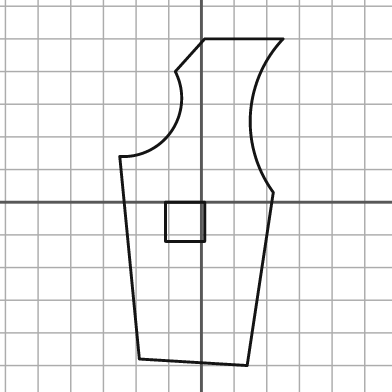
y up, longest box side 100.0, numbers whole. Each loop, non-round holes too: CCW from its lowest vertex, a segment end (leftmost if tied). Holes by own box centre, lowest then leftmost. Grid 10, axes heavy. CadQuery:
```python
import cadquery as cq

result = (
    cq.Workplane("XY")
    .moveTo(14.0, -50.0)
    .lineTo(22.0, 3.0)
    .threePointArc((15.0, 27.0), (25.0, 50.0))
    .lineTo(1.0, 50.0)
    .lineTo(-8.0, 40.0)
    .threePointArc((-9.0, 22.0), (-25.0, 14.0))
    .lineTo(-19.0, -48.0)
    .close()
    .moveTo(-11.0, -12.0)
    .lineTo(1.0, -12.0)
    .lineTo(1.0, 0.0)
    .lineTo(-11.0, 0.0)
    .close()
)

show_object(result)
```